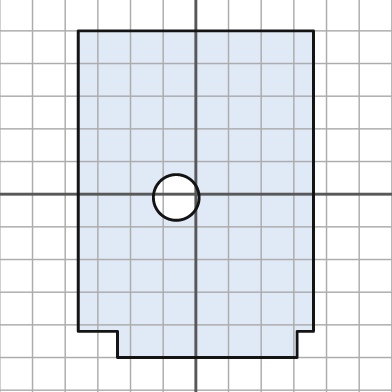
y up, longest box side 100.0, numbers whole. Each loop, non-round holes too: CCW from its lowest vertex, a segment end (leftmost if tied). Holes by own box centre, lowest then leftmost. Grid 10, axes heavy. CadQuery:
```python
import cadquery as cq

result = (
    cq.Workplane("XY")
    .moveTo(-24.0, -50.0)
    .lineTo(31.0, -50.0)
    .lineTo(31.0, -42.0)
    .lineTo(36.0, -42.0)
    .lineTo(36.0, 50.0)
    .lineTo(-36.0, 50.0)
    .lineTo(-36.0, -42.0)
    .lineTo(-24.0, -42.0)
    .close()
    .moveTo(-6.0, -1.0)
    .circle(7.0)
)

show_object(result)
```